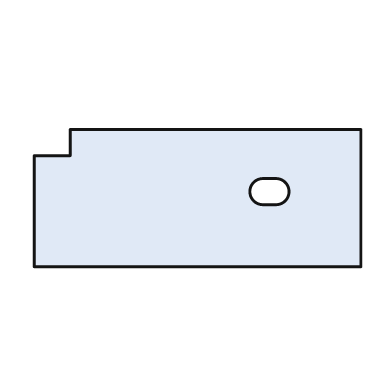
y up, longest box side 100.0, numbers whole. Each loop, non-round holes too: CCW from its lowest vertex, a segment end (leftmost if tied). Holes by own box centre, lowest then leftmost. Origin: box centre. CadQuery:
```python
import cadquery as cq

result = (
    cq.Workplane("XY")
    .moveTo(-50.0, -21.0)
    .lineTo(50.0, -21.0)
    .lineTo(50.0, 21.0)
    .lineTo(-39.0, 21.0)
    .lineTo(-39.0, 13.0)
    .lineTo(-50.0, 13.0)
    .close()
    .moveTo(20.0, -2.0)
    .lineTo(24.0, -2.0)
    .threePointArc((28.0, 2.0), (24.0, 6.0))
    .lineTo(20.0, 6.0)
    .threePointArc((16.0, 2.0), (20.0, -2.0))
    .close()
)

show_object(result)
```